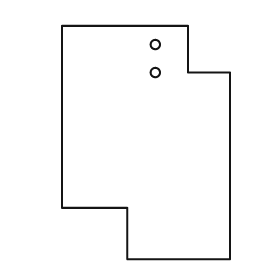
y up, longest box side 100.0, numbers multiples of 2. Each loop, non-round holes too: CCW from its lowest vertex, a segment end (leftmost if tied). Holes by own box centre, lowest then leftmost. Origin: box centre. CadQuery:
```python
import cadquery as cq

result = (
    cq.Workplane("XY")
    .moveTo(-8.0, -50.0)
    .lineTo(36.0, -50.0)
    .lineTo(36.0, 30.0)
    .lineTo(18.0, 30.0)
    .lineTo(18.0, 50.0)
    .lineTo(-36.0, 50.0)
    .lineTo(-36.0, -28.0)
    .lineTo(-8.0, -28.0)
    .close()
    .moveTo(4.0, 30.0)
    .circle(2.0)
    .moveTo(4.0, 42.0)
    .circle(2.0)
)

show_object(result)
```